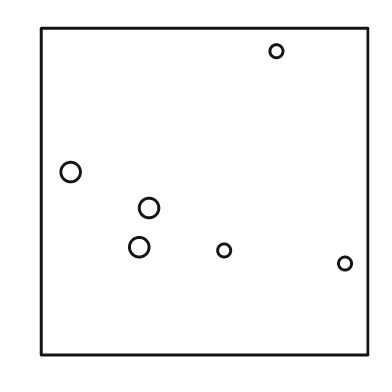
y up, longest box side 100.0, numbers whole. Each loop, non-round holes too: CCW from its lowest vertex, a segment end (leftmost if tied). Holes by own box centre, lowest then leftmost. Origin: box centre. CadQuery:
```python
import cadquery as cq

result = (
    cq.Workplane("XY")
    .moveTo(-50.0, -50.0)
    .lineTo(50.0, -50.0)
    .lineTo(50.0, 50.0)
    .lineTo(-50.0, 50.0)
    .close()
    .moveTo(43.0, -22.0)
    .circle(2.0)
    .moveTo(6.0, -18.0)
    .circle(2.0)
    .moveTo(-20.0, -17.0)
    .circle(3.0)
    .moveTo(-17.0, -5.0)
    .circle(3.0)
    .moveTo(-41.0, 6.0)
    .circle(3.0)
    .moveTo(22.0, 43.0)
    .circle(2.0)
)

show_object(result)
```